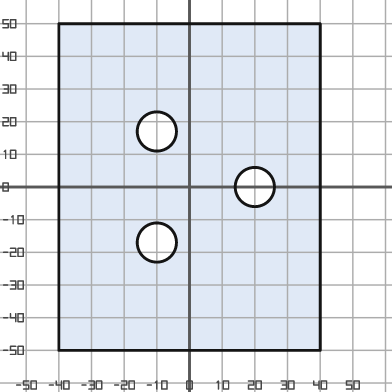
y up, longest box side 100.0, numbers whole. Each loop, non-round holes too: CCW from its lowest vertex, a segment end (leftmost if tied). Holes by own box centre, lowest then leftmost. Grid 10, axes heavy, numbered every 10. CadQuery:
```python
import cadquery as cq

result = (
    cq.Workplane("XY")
    .moveTo(-40.0, -50.0)
    .lineTo(40.0, -50.0)
    .lineTo(40.0, 50.0)
    .lineTo(-40.0, 50.0)
    .close()
    .moveTo(-10.0, -17.0)
    .circle(6.0)
    .moveTo(20.0, 0.0)
    .circle(6.0)
    .moveTo(-10.0, 17.0)
    .circle(6.0)
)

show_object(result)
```